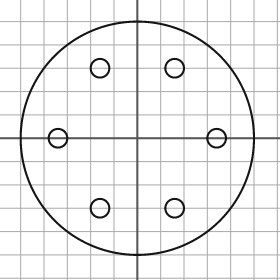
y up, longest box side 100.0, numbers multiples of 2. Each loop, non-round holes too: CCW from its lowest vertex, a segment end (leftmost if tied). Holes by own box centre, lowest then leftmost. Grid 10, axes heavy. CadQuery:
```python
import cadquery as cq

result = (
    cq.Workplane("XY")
    .moveTo(0.0, 0.0)
    .circle(50.0)
    .moveTo(-16.0, -30.0)
    .circle(4.0)
    .moveTo(16.0, -30.0)
    .circle(4.0)
    .moveTo(-34.0, 0.0)
    .circle(4.0)
    .moveTo(34.0, 0.0)
    .circle(4.0)
    .moveTo(-16.0, 30.0)
    .circle(4.0)
    .moveTo(16.0, 30.0)
    .circle(4.0)
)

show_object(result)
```